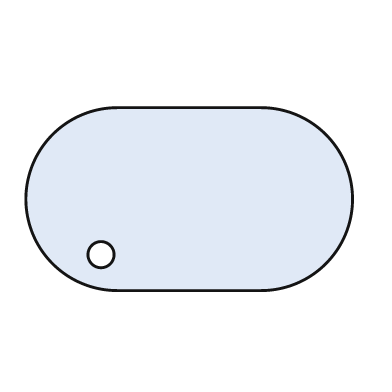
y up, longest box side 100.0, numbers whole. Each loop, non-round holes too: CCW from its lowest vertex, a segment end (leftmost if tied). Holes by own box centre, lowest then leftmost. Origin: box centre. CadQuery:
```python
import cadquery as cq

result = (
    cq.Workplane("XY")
    .moveTo(-22.0, -28.0)
    .lineTo(22.0, -28.0)
    .threePointArc((50.0, 0.0), (22.0, 28.0))
    .lineTo(-22.0, 28.0)
    .threePointArc((-50.0, 0.0), (-22.0, -28.0))
    .close()
    .moveTo(-27.0, -17.0)
    .circle(4.0)
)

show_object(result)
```